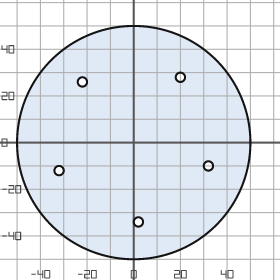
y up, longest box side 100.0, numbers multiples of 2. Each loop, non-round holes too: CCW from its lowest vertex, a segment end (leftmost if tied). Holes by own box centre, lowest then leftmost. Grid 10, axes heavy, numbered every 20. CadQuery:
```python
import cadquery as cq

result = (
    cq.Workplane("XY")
    .moveTo(0.0, 0.0)
    .circle(50.0)
    .moveTo(2.0, -34.0)
    .circle(2.0)
    .moveTo(-32.0, -12.0)
    .circle(2.0)
    .moveTo(32.0, -10.0)
    .circle(2.0)
    .moveTo(-22.0, 26.0)
    .circle(2.0)
    .moveTo(20.0, 28.0)
    .circle(2.0)
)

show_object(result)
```